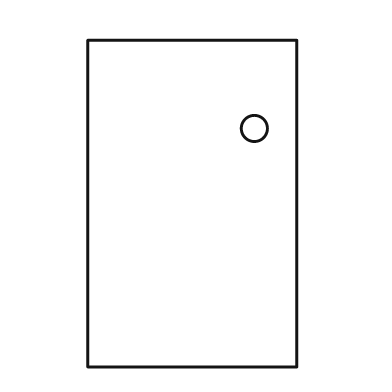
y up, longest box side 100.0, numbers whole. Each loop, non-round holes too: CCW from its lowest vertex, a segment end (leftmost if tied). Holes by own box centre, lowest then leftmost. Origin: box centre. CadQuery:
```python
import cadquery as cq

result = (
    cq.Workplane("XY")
    .moveTo(-32.0, -50.0)
    .lineTo(32.0, -50.0)
    .lineTo(32.0, 50.0)
    .lineTo(-32.0, 50.0)
    .close()
    .moveTo(19.0, 23.0)
    .circle(4.0)
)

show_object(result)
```